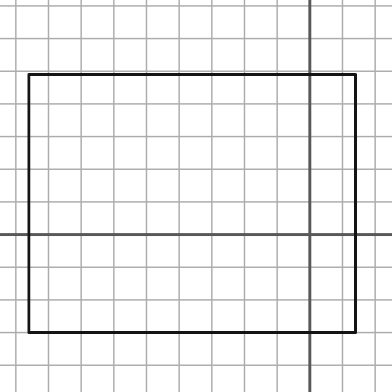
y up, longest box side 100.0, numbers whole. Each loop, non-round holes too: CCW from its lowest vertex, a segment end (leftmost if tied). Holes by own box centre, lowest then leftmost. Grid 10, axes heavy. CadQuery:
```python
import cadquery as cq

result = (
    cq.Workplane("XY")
    .moveTo(-86.0, -30.0)
    .lineTo(14.0, -30.0)
    .lineTo(14.0, 49.0)
    .lineTo(-86.0, 49.0)
    .close()
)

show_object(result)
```